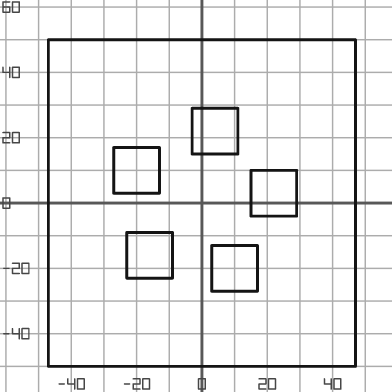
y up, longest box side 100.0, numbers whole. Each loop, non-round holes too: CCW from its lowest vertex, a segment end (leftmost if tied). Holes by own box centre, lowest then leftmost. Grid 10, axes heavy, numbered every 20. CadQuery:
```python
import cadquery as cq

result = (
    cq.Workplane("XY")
    .moveTo(-47.0, -50.0)
    .lineTo(47.0, -50.0)
    .lineTo(47.0, 50.0)
    .lineTo(-47.0, 50.0)
    .close()
    .moveTo(3.0, -27.0)
    .lineTo(17.0, -27.0)
    .lineTo(17.0, -13.0)
    .lineTo(3.0, -13.0)
    .close()
    .moveTo(-23.0, -23.0)
    .lineTo(-9.0, -23.0)
    .lineTo(-9.0, -9.0)
    .lineTo(-23.0, -9.0)
    .close()
    .moveTo(15.0, -4.0)
    .lineTo(29.0, -4.0)
    .lineTo(29.0, 10.0)
    .lineTo(15.0, 10.0)
    .close()
    .moveTo(-27.0, 3.0)
    .lineTo(-13.0, 3.0)
    .lineTo(-13.0, 17.0)
    .lineTo(-27.0, 17.0)
    .close()
    .moveTo(-3.0, 15.0)
    .lineTo(11.0, 15.0)
    .lineTo(11.0, 29.0)
    .lineTo(-3.0, 29.0)
    .close()
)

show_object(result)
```